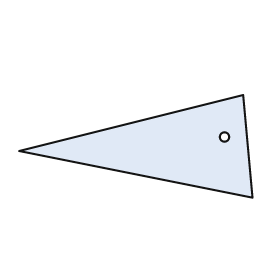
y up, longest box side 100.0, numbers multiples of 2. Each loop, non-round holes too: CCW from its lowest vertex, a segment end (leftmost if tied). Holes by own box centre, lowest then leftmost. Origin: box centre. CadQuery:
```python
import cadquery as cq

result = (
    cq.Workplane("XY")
    .moveTo(50.0, -22.0)
    .lineTo(46.0, 22.0)
    .lineTo(-50.0, -2.0)
    .close()
    .moveTo(38.0, 4.0)
    .circle(2.0)
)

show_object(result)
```